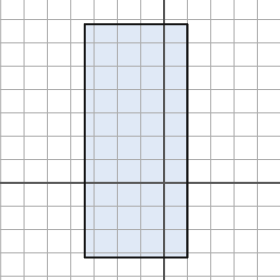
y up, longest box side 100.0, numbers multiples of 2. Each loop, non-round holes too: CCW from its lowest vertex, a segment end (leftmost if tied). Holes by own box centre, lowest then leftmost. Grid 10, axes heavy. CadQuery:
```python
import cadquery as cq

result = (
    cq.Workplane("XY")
    .moveTo(-34.0, -32.0)
    .lineTo(10.0, -32.0)
    .lineTo(10.0, 68.0)
    .lineTo(-34.0, 68.0)
    .close()
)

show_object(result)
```